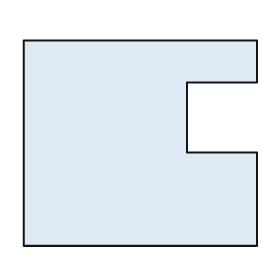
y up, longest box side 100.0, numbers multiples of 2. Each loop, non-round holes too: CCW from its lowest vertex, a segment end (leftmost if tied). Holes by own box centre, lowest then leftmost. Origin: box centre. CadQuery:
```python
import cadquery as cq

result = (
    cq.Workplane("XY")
    .moveTo(-50.0, -44.0)
    .lineTo(50.0, -44.0)
    .lineTo(50.0, -4.0)
    .lineTo(20.0, -4.0)
    .lineTo(20.0, 26.0)
    .lineTo(50.0, 26.0)
    .lineTo(50.0, 44.0)
    .lineTo(-50.0, 44.0)
    .close()
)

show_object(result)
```